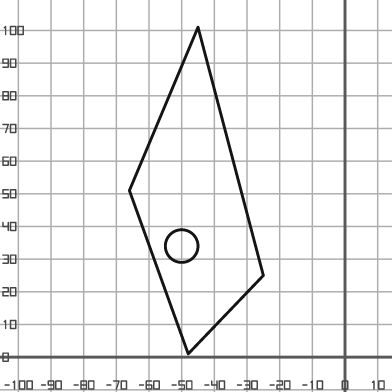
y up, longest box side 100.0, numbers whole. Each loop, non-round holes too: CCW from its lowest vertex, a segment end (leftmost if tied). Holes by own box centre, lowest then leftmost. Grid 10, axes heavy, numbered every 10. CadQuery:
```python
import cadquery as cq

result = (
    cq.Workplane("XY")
    .moveTo(-48.0, 1.0)
    .lineTo(-25.0, 25.0)
    .lineTo(-45.0, 101.0)
    .lineTo(-66.0, 51.0)
    .close()
    .moveTo(-50.0, 34.0)
    .circle(5.0)
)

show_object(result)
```